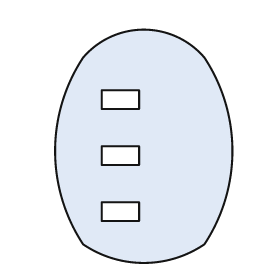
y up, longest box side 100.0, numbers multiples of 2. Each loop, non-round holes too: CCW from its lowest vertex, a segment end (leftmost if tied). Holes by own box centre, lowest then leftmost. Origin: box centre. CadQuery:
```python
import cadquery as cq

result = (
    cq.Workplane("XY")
    .moveTo(-26.0, -42.0)
    .threePointArc((0.0, -50.0), (26.0, -42.0))
    .threePointArc((38.0, -2.0), (26.0, 38.0))
    .threePointArc((0.0, 50.0), (-26.0, 38.0))
    .threePointArc((-38.0, -2.0), (-26.0, -42.0))
    .close()
    .moveTo(-18.0, -32.0)
    .lineTo(-2.0, -32.0)
    .lineTo(-2.0, -24.0)
    .lineTo(-18.0, -24.0)
    .close()
    .moveTo(-18.0, -8.0)
    .lineTo(-2.0, -8.0)
    .lineTo(-2.0, 0.0)
    .lineTo(-18.0, 0.0)
    .close()
    .moveTo(-18.0, 16.0)
    .lineTo(-2.0, 16.0)
    .lineTo(-2.0, 24.0)
    .lineTo(-18.0, 24.0)
    .close()
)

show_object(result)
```